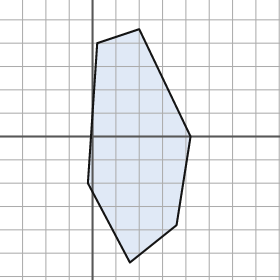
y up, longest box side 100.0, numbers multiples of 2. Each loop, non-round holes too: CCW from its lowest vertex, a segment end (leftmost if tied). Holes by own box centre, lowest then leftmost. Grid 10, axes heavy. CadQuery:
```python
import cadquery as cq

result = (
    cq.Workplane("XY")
    .moveTo(16.0, -54.0)
    .lineTo(36.0, -38.0)
    .lineTo(42.0, 0.0)
    .lineTo(20.0, 46.0)
    .lineTo(2.0, 40.0)
    .lineTo(-2.0, -20.0)
    .close()
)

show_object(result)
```